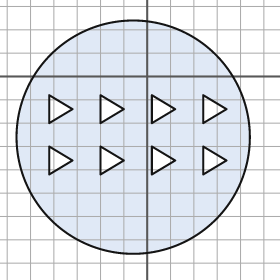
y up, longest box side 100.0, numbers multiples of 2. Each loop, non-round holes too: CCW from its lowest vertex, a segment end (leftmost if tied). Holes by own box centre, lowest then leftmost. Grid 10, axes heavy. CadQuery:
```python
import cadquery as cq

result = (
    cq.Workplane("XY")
    .moveTo(-6.0, -26.0)
    .circle(50.0)
    .moveTo(-42.0, -42.0)
    .lineTo(-32.0, -36.0)
    .lineTo(-42.0, -30.0)
    .close()
    .moveTo(-20.0, -42.0)
    .lineTo(-10.0, -36.0)
    .lineTo(-20.0, -30.0)
    .close()
    .moveTo(2.0, -42.0)
    .lineTo(12.0, -36.0)
    .lineTo(2.0, -30.0)
    .close()
    .moveTo(24.0, -42.0)
    .lineTo(34.0, -36.0)
    .lineTo(24.0, -30.0)
    .close()
    .moveTo(-42.0, -20.0)
    .lineTo(-32.0, -14.0)
    .lineTo(-42.0, -8.0)
    .close()
    .moveTo(-20.0, -20.0)
    .lineTo(-10.0, -14.0)
    .lineTo(-20.0, -8.0)
    .close()
    .moveTo(2.0, -20.0)
    .lineTo(12.0, -14.0)
    .lineTo(2.0, -8.0)
    .close()
    .moveTo(24.0, -20.0)
    .lineTo(34.0, -14.0)
    .lineTo(24.0, -8.0)
    .close()
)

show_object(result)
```